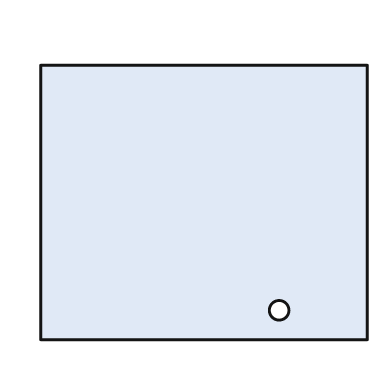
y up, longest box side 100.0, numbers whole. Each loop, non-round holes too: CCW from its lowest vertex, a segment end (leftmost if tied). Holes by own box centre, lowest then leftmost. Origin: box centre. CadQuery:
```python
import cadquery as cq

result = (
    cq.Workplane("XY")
    .moveTo(-50.0, -42.0)
    .lineTo(50.0, -42.0)
    .lineTo(50.0, 42.0)
    .lineTo(-50.0, 42.0)
    .close()
    .moveTo(23.0, -33.0)
    .circle(3.0)
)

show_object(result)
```